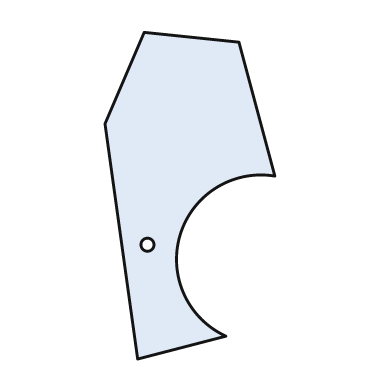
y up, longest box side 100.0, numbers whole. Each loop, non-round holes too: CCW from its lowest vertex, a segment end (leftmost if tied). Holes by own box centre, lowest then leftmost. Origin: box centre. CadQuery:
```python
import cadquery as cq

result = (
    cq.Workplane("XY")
    .moveTo(-16.0, -50.0)
    .lineTo(11.0, -43.0)
    .threePointArc((-3.0, -12.0), (26.0, 6.0))
    .lineTo(15.0, 47.0)
    .lineTo(-14.0, 50.0)
    .lineTo(-26.0, 22.0)
    .close()
    .moveTo(-13.0, -15.0)
    .circle(2.0)
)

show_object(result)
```